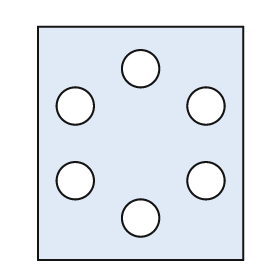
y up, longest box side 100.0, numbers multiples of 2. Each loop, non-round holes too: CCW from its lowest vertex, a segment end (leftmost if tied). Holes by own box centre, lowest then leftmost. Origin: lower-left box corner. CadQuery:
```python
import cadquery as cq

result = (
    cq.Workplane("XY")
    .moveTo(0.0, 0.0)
    .lineTo(88.0, 0.0)
    .lineTo(88.0, 100.0)
    .lineTo(0.0, 100.0)
    .close()
    .moveTo(44.0, 18.0)
    .circle(8.0)
    .moveTo(16.0, 34.0)
    .circle(8.0)
    .moveTo(72.0, 34.0)
    .circle(8.0)
    .moveTo(16.0, 66.0)
    .circle(8.0)
    .moveTo(72.0, 66.0)
    .circle(8.0)
    .moveTo(44.0, 82.0)
    .circle(8.0)
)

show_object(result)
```